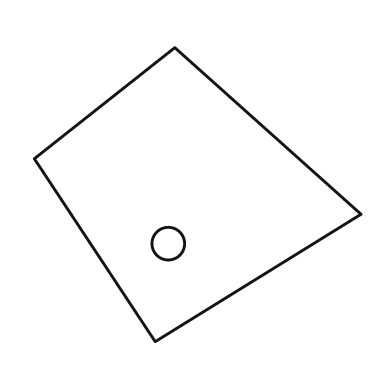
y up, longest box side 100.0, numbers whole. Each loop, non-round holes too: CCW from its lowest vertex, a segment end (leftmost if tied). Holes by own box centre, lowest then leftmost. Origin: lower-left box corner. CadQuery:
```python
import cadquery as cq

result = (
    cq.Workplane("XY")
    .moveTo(37.0, 0.0)
    .lineTo(100.0, 39.0)
    .lineTo(43.0, 90.0)
    .lineTo(0.0, 56.0)
    .close()
    .moveTo(41.0, 30.0)
    .circle(5.0)
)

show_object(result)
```